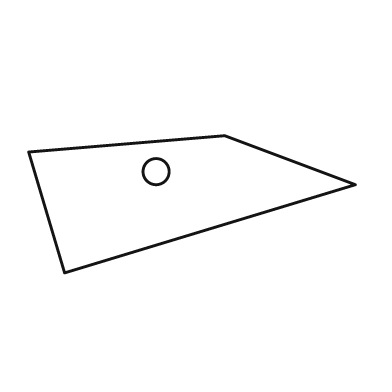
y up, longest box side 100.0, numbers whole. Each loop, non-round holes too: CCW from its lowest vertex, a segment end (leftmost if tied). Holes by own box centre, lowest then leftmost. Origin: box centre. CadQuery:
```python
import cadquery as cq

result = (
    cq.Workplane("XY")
    .moveTo(-39.0, -21.0)
    .lineTo(50.0, 6.0)
    .lineTo(10.0, 21.0)
    .lineTo(-50.0, 16.0)
    .close()
    .moveTo(-11.0, 10.0)
    .circle(4.0)
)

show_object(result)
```